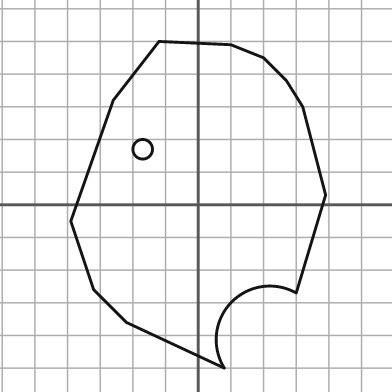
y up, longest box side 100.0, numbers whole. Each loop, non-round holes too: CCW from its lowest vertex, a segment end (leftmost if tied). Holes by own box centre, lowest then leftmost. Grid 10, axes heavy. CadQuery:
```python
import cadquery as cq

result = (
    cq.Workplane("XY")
    .moveTo(8.0, -50.0)
    .threePointArc((10.0, -30.0), (30.0, -27.0))
    .lineTo(39.0, 3.0)
    .lineTo(32.0, 30.0)
    .lineTo(27.0, 38.0)
    .lineTo(20.0, 45.0)
    .lineTo(10.0, 49.0)
    .lineTo(-12.0, 50.0)
    .lineTo(-26.0, 32.0)
    .lineTo(-39.0, -5.0)
    .lineTo(-32.0, -26.0)
    .lineTo(-22.0, -36.0)
    .close()
    .moveTo(-17.0, 17.0)
    .circle(3.0)
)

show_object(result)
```